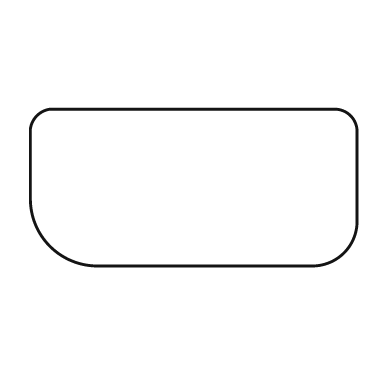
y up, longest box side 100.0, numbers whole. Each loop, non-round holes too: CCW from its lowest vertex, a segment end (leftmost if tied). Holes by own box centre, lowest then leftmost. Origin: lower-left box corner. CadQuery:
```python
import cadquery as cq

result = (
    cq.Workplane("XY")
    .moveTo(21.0, 0.0)
    .lineTo(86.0, 0.0)
    .threePointArc((96.0, 4.0), (100.0, 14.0))
    .lineTo(100.0, 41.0)
    .threePointArc((98.0, 46.0), (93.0, 48.0))
    .lineTo(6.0, 48.0)
    .threePointArc((2.0, 46.0), (0.0, 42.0))
    .lineTo(0.0, 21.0)
    .threePointArc((6.0, 6.0), (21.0, 0.0))
    .close()
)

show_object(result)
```